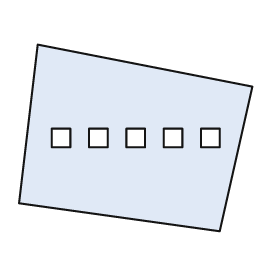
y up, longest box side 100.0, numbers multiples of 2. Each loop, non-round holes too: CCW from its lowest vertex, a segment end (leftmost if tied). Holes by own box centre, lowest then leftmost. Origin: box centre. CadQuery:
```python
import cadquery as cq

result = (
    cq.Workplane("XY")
    .moveTo(36.0, -40.0)
    .lineTo(50.0, 22.0)
    .lineTo(-42.0, 40.0)
    .lineTo(-50.0, -28.0)
    .close()
    .moveTo(-36.0, -4.0)
    .lineTo(-28.0, -4.0)
    .lineTo(-28.0, 4.0)
    .lineTo(-36.0, 4.0)
    .close()
    .moveTo(-20.0, -4.0)
    .lineTo(-12.0, -4.0)
    .lineTo(-12.0, 4.0)
    .lineTo(-20.0, 4.0)
    .close()
    .moveTo(-4.0, -4.0)
    .lineTo(4.0, -4.0)
    .lineTo(4.0, 4.0)
    .lineTo(-4.0, 4.0)
    .close()
    .moveTo(12.0, -4.0)
    .lineTo(20.0, -4.0)
    .lineTo(20.0, 4.0)
    .lineTo(12.0, 4.0)
    .close()
    .moveTo(28.0, -4.0)
    .lineTo(36.0, -4.0)
    .lineTo(36.0, 4.0)
    .lineTo(28.0, 4.0)
    .close()
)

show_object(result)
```